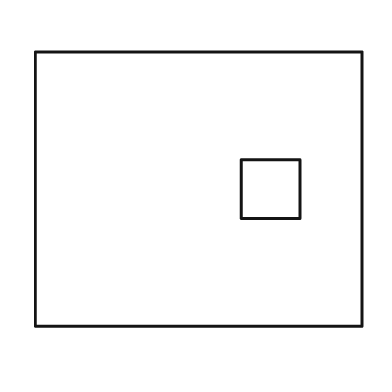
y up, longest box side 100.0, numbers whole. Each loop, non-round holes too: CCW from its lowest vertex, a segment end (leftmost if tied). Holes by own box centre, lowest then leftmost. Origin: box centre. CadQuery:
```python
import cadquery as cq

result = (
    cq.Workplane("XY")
    .moveTo(-50.0, -42.0)
    .lineTo(50.0, -42.0)
    .lineTo(50.0, 42.0)
    .lineTo(-50.0, 42.0)
    .close()
    .moveTo(13.0, -9.0)
    .lineTo(31.0, -9.0)
    .lineTo(31.0, 9.0)
    .lineTo(13.0, 9.0)
    .close()
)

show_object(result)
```